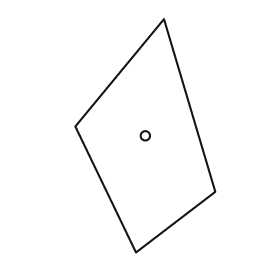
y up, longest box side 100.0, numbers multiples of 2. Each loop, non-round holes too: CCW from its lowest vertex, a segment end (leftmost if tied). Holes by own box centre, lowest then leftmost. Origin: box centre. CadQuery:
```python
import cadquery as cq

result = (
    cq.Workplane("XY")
    .moveTo(-4.0, -50.0)
    .lineTo(30.0, -24.0)
    .lineTo(8.0, 50.0)
    .lineTo(-30.0, 4.0)
    .close()
    .moveTo(0.0, 0.0)
    .circle(2.0)
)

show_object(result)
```